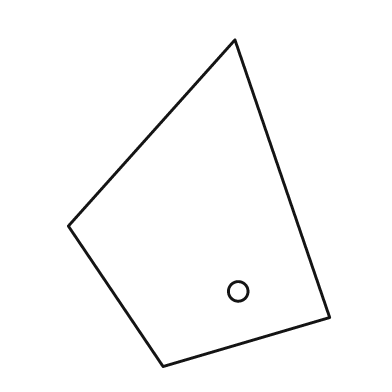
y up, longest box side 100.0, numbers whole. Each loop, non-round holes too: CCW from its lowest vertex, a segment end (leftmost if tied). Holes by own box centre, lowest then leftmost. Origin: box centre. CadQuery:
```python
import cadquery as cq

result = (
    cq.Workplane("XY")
    .moveTo(-11.0, -50.0)
    .lineTo(40.0, -35.0)
    .lineTo(11.0, 50.0)
    .lineTo(-40.0, -7.0)
    .close()
    .moveTo(12.0, -27.0)
    .circle(3.0)
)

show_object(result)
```